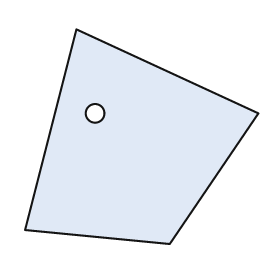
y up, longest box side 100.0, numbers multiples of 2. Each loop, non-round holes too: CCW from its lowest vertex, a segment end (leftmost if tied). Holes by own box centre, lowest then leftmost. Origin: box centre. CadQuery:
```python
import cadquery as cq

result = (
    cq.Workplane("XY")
    .moveTo(12.0, -46.0)
    .lineTo(50.0, 10.0)
    .lineTo(-28.0, 46.0)
    .lineTo(-50.0, -40.0)
    .close()
    .moveTo(-20.0, 10.0)
    .circle(4.0)
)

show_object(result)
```